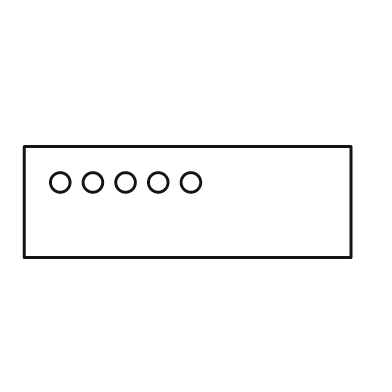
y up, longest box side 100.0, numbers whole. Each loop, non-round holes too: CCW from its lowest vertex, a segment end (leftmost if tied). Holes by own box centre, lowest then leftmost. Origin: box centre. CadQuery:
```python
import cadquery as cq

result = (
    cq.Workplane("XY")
    .moveTo(-50.0, -17.0)
    .lineTo(50.0, -17.0)
    .lineTo(50.0, 17.0)
    .lineTo(-50.0, 17.0)
    .close()
    .moveTo(-39.0, 6.0)
    .circle(3.0)
    .moveTo(-29.0, 6.0)
    .circle(3.0)
    .moveTo(-19.0, 6.0)
    .circle(3.0)
    .moveTo(-9.0, 6.0)
    .circle(3.0)
    .moveTo(1.0, 6.0)
    .circle(3.0)
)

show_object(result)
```